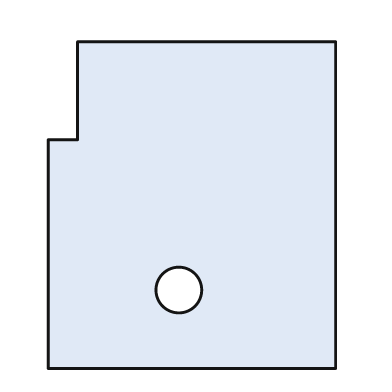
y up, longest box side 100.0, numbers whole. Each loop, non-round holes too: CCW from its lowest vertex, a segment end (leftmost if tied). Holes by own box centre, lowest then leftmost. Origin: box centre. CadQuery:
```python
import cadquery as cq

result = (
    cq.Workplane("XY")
    .moveTo(-44.0, -50.0)
    .lineTo(44.0, -50.0)
    .lineTo(44.0, 50.0)
    .lineTo(-35.0, 50.0)
    .lineTo(-35.0, 20.0)
    .lineTo(-44.0, 20.0)
    .close()
    .moveTo(-4.0, -26.0)
    .circle(7.0)
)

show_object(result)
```